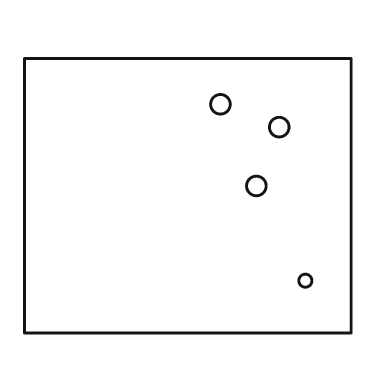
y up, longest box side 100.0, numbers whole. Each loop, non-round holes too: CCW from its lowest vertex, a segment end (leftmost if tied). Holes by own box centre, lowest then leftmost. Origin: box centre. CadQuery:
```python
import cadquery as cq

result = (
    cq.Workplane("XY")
    .moveTo(-50.0, -42.0)
    .lineTo(50.0, -42.0)
    .lineTo(50.0, 42.0)
    .lineTo(-50.0, 42.0)
    .close()
    .moveTo(36.0, -26.0)
    .circle(2.0)
    .moveTo(21.0, 3.0)
    .circle(3.0)
    .moveTo(28.0, 21.0)
    .circle(3.0)
    .moveTo(10.0, 28.0)
    .circle(3.0)
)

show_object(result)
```